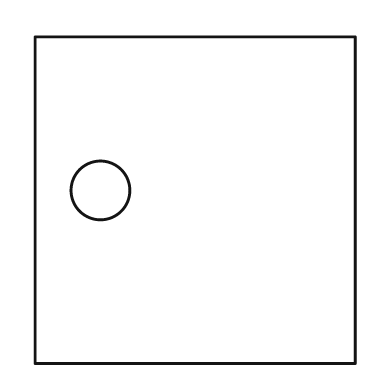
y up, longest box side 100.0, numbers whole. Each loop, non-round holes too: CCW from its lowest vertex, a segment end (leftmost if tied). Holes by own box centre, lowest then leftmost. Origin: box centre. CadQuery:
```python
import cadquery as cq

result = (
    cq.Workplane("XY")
    .moveTo(-49.0, -50.0)
    .lineTo(49.0, -50.0)
    .lineTo(49.0, 50.0)
    .lineTo(-49.0, 50.0)
    .close()
    .moveTo(-29.0, 3.0)
    .circle(9.0)
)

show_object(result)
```